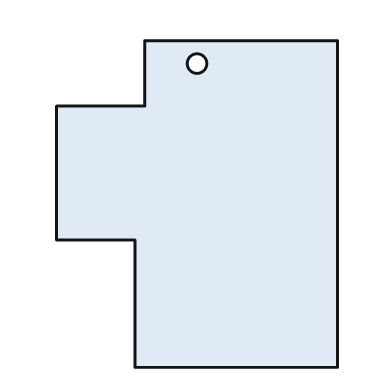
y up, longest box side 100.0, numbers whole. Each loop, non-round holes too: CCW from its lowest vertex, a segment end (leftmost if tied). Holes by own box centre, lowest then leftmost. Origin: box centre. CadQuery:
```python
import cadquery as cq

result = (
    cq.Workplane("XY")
    .moveTo(-19.0, -50.0)
    .lineTo(43.0, -50.0)
    .lineTo(43.0, 50.0)
    .lineTo(-16.0, 50.0)
    .lineTo(-16.0, 30.0)
    .lineTo(-43.0, 30.0)
    .lineTo(-43.0, -11.0)
    .lineTo(-19.0, -11.0)
    .close()
    .moveTo(0.0, 43.0)
    .circle(3.0)
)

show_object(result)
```